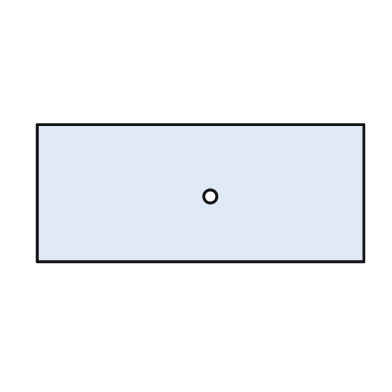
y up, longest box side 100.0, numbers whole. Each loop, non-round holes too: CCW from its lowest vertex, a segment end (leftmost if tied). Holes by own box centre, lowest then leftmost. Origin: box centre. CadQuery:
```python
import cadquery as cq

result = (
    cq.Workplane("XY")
    .moveTo(-50.0, -21.0)
    .lineTo(50.0, -21.0)
    .lineTo(50.0, 21.0)
    .lineTo(-50.0, 21.0)
    .close()
    .moveTo(3.0, -1.0)
    .circle(2.0)
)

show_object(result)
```